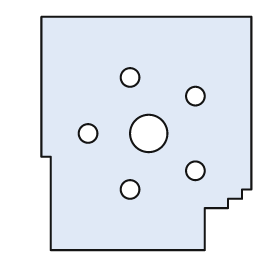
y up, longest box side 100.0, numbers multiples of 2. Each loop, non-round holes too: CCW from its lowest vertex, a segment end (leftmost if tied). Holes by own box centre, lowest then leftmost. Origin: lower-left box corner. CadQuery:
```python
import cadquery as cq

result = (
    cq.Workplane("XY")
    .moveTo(4.0, 0.0)
    .lineTo(70.0, 0.0)
    .lineTo(70.0, 18.0)
    .lineTo(80.0, 18.0)
    .lineTo(80.0, 22.0)
    .lineTo(86.0, 22.0)
    .lineTo(86.0, 26.0)
    .lineTo(90.0, 26.0)
    .lineTo(90.0, 100.0)
    .lineTo(0.0, 100.0)
    .lineTo(0.0, 40.0)
    .lineTo(4.0, 40.0)
    .close()
    .moveTo(38.0, 26.0)
    .circle(4.0)
    .moveTo(66.0, 34.0)
    .circle(4.0)
    .moveTo(20.0, 50.0)
    .circle(4.0)
    .moveTo(46.0, 50.0)
    .circle(8.0)
    .moveTo(66.0, 66.0)
    .circle(4.0)
    .moveTo(38.0, 74.0)
    .circle(4.0)
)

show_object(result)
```